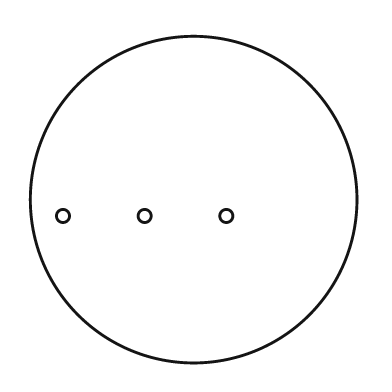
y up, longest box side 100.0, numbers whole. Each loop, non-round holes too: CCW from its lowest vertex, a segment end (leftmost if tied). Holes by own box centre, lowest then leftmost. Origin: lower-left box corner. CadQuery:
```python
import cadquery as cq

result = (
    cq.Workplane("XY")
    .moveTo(50.0, 50.0)
    .circle(50.0)
    .moveTo(10.0, 45.0)
    .circle(2.0)
    .moveTo(35.0, 45.0)
    .circle(2.0)
    .moveTo(60.0, 45.0)
    .circle(2.0)
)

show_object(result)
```